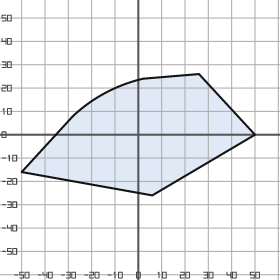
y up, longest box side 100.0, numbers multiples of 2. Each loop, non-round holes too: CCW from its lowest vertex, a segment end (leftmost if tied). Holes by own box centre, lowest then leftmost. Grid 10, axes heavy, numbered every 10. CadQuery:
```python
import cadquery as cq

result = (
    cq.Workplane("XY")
    .moveTo(6.0, -26.0)
    .lineTo(50.0, 0.0)
    .lineTo(26.0, 26.0)
    .lineTo(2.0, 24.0)
    .threePointArc((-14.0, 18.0), (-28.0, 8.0))
    .lineTo(-50.0, -16.0)
    .close()
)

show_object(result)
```